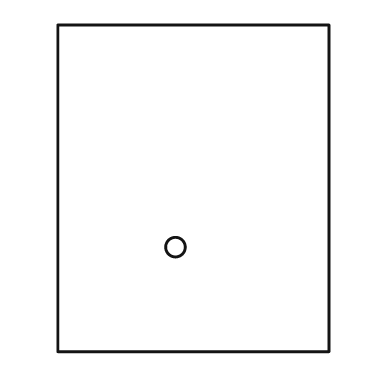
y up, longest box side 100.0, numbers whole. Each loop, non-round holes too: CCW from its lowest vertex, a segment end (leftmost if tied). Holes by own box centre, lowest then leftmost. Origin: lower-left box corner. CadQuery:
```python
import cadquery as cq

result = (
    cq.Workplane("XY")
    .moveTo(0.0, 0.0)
    .lineTo(83.0, 0.0)
    .lineTo(83.0, 100.0)
    .lineTo(0.0, 100.0)
    .close()
    .moveTo(36.0, 32.0)
    .circle(3.0)
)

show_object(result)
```